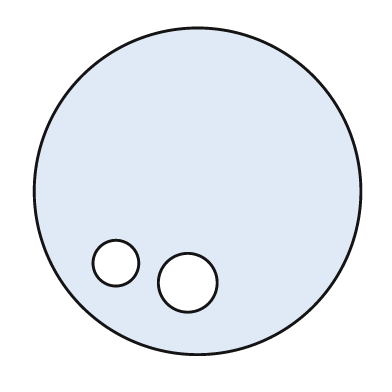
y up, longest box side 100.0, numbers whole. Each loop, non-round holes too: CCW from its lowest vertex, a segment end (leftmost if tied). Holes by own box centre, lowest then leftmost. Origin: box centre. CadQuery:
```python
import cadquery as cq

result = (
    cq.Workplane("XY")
    .moveTo(0.0, 0.0)
    .circle(50.0)
    .moveTo(-3.0, -28.0)
    .circle(9.0)
    .moveTo(-25.0, -22.0)
    .circle(7.0)
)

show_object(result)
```